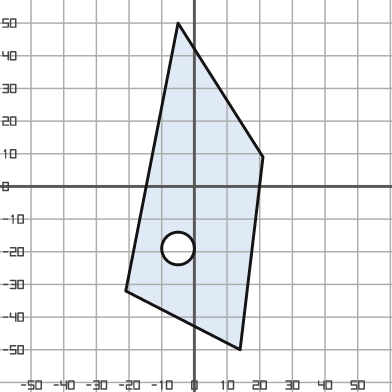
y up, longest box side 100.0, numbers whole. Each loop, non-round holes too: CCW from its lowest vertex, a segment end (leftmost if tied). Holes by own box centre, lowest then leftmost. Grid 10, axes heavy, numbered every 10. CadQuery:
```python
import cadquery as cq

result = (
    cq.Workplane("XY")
    .moveTo(14.0, -50.0)
    .lineTo(21.0, 9.0)
    .lineTo(-5.0, 50.0)
    .lineTo(-21.0, -32.0)
    .close()
    .moveTo(-5.0, -19.0)
    .circle(5.0)
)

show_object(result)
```